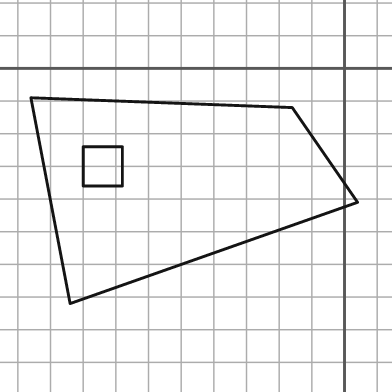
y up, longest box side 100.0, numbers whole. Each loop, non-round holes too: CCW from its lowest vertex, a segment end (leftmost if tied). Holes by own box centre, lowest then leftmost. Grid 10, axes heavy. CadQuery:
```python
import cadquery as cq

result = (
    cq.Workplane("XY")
    .moveTo(-84.0, -72.0)
    .lineTo(4.0, -41.0)
    .lineTo(-16.0, -12.0)
    .lineTo(-96.0, -9.0)
    .close()
    .moveTo(-80.0, -36.0)
    .lineTo(-68.0, -36.0)
    .lineTo(-68.0, -24.0)
    .lineTo(-80.0, -24.0)
    .close()
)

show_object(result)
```